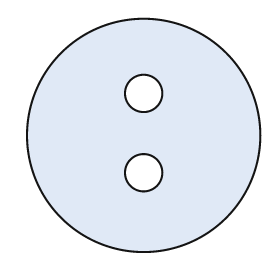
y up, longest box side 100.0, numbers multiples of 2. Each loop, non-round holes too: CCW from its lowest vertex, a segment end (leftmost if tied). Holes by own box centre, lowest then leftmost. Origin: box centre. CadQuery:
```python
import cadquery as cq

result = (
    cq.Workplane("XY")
    .moveTo(0.0, 0.0)
    .circle(50.0)
    .moveTo(0.0, -16.0)
    .circle(8.0)
    .moveTo(0.0, 18.0)
    .circle(8.0)
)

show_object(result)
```